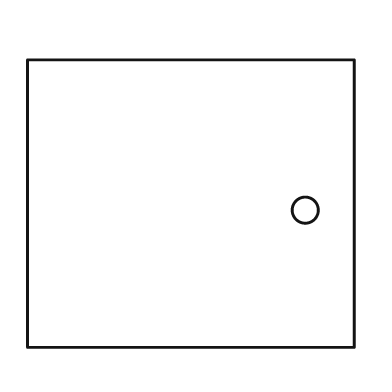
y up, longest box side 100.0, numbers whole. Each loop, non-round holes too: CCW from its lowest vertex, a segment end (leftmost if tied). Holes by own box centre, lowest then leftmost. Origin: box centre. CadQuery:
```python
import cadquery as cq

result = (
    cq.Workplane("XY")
    .moveTo(-50.0, -44.0)
    .lineTo(50.0, -44.0)
    .lineTo(50.0, 44.0)
    .lineTo(-50.0, 44.0)
    .close()
    .moveTo(35.0, -2.0)
    .circle(4.0)
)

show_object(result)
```